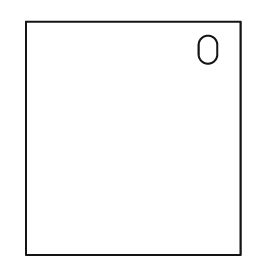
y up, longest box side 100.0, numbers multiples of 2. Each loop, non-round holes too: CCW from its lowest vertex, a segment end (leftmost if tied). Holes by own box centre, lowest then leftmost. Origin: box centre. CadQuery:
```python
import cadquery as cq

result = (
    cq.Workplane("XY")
    .moveTo(-46.0, -50.0)
    .lineTo(46.0, -50.0)
    .lineTo(46.0, 50.0)
    .lineTo(-46.0, 50.0)
    .close()
    .moveTo(28.0, 36.0)
    .threePointArc((32.0, 32.0), (36.0, 36.0))
    .lineTo(36.0, 40.0)
    .threePointArc((32.0, 44.0), (28.0, 40.0))
    .close()
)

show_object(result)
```